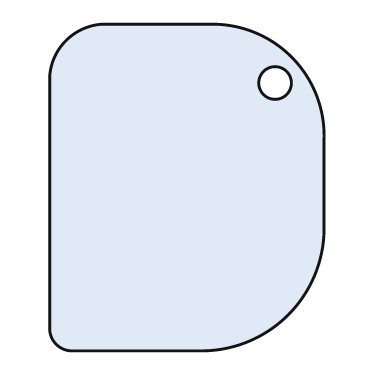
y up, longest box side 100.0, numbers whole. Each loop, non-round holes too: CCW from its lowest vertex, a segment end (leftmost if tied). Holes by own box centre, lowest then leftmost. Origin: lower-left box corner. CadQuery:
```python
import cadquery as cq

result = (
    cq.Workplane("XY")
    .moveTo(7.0, 0.0)
    .lineTo(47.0, 0.0)
    .threePointArc((73.0, 11.0), (84.0, 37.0))
    .lineTo(84.0, 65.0)
    .threePointArc((74.0, 90.0), (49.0, 100.0))
    .lineTo(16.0, 100.0)
    .threePointArc((5.0, 95.0), (0.0, 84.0))
    .lineTo(0.0, 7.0)
    .threePointArc((2.0, 2.0), (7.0, 0.0))
    .close()
    .moveTo(69.0, 82.0)
    .circle(5.0)
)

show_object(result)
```